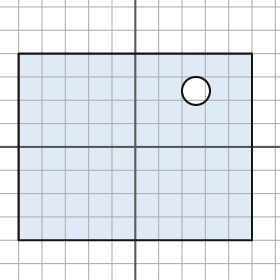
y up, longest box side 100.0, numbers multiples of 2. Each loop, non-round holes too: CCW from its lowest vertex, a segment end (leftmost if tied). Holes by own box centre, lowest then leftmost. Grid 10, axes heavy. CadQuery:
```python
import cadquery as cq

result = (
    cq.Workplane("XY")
    .moveTo(-50.0, -40.0)
    .lineTo(50.0, -40.0)
    .lineTo(50.0, 40.0)
    .lineTo(-50.0, 40.0)
    .close()
    .moveTo(26.0, 24.0)
    .circle(6.0)
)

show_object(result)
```